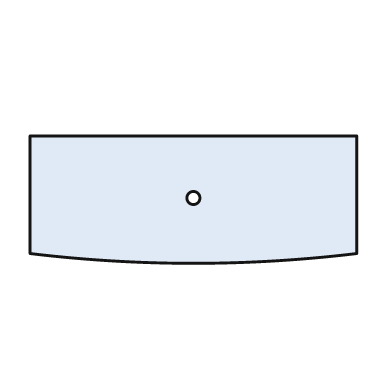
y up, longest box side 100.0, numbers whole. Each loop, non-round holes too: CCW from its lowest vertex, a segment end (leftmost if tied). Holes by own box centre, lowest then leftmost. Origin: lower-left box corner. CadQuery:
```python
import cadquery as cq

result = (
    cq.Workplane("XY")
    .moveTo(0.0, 3.0)
    .threePointArc((50.0, 0.0), (100.0, 3.0))
    .lineTo(100.0, 39.0)
    .lineTo(0.0, 39.0)
    .close()
    .moveTo(50.0, 20.0)
    .circle(2.0)
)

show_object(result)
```